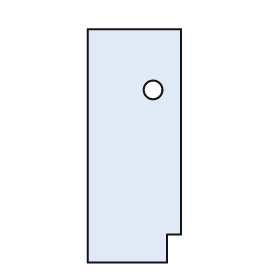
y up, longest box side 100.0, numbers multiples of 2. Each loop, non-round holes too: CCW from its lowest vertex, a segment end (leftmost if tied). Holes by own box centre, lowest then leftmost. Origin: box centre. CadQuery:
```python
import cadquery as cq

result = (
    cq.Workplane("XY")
    .moveTo(-20.0, -50.0)
    .lineTo(14.0, -50.0)
    .lineTo(14.0, -38.0)
    .lineTo(20.0, -38.0)
    .lineTo(20.0, 50.0)
    .lineTo(-20.0, 50.0)
    .close()
    .moveTo(8.0, 24.0)
    .circle(4.0)
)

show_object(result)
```